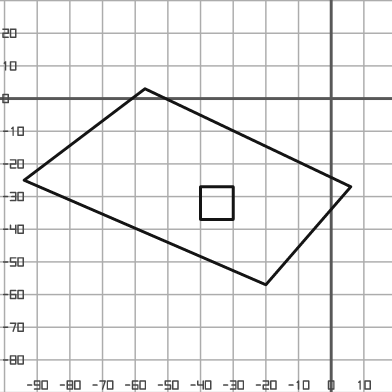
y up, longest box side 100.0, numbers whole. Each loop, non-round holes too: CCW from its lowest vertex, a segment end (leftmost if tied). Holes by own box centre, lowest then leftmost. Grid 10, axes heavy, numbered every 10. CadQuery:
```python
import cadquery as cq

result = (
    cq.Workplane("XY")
    .moveTo(-20.0, -57.0)
    .lineTo(6.0, -27.0)
    .lineTo(-57.0, 3.0)
    .lineTo(-94.0, -25.0)
    .close()
    .moveTo(-40.0, -37.0)
    .lineTo(-30.0, -37.0)
    .lineTo(-30.0, -27.0)
    .lineTo(-40.0, -27.0)
    .close()
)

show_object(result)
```